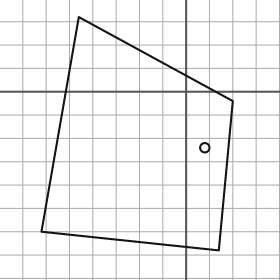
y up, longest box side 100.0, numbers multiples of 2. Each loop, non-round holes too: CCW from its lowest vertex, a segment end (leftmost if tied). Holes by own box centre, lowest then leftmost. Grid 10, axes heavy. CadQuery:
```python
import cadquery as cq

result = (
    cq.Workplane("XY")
    .moveTo(14.0, -68.0)
    .lineTo(20.0, -4.0)
    .lineTo(-46.0, 32.0)
    .lineTo(-62.0, -60.0)
    .close()
    .moveTo(8.0, -24.0)
    .circle(2.0)
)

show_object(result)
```